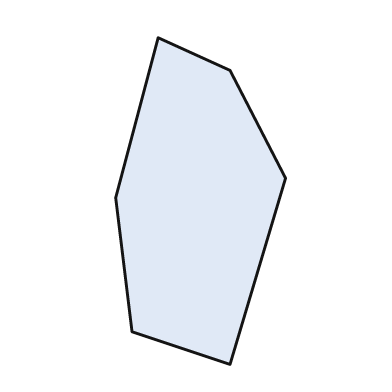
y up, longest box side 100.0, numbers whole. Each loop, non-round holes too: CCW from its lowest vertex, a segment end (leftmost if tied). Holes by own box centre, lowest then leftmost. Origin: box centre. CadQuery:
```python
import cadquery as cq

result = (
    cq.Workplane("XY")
    .moveTo(9.0, -50.0)
    .lineTo(26.0, 7.0)
    .lineTo(9.0, 40.0)
    .lineTo(-13.0, 50.0)
    .lineTo(-26.0, 1.0)
    .lineTo(-21.0, -40.0)
    .close()
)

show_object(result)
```